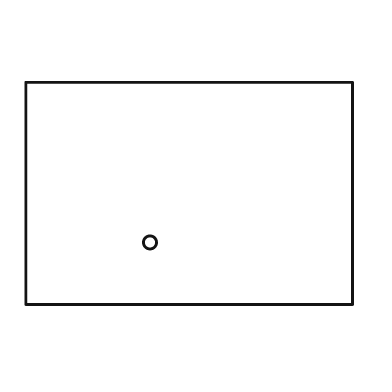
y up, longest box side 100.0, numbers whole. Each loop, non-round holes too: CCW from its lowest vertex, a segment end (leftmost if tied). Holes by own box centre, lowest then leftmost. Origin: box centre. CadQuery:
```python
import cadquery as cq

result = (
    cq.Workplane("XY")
    .moveTo(-50.0, -34.0)
    .lineTo(50.0, -34.0)
    .lineTo(50.0, 34.0)
    .lineTo(-50.0, 34.0)
    .close()
    .moveTo(-12.0, -15.0)
    .circle(2.0)
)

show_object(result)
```